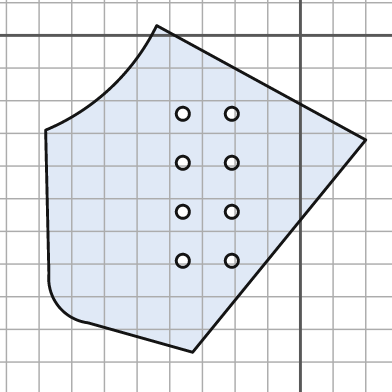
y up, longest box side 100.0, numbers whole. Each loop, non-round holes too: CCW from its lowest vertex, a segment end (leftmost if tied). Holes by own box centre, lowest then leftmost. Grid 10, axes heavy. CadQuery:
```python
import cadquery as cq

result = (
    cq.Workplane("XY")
    .moveTo(-33.0, -97.0)
    .lineTo(20.0, -32.0)
    .lineTo(-44.0, 3.0)
    .threePointArc((-58.0, -16.0), (-78.0, -29.0))
    .lineTo(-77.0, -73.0)
    .threePointArc((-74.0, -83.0), (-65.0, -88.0))
    .close()
    .moveTo(-36.0, -69.0)
    .circle(2.0)
    .moveTo(-21.0, -69.0)
    .circle(2.0)
    .moveTo(-36.0, -54.0)
    .circle(2.0)
    .moveTo(-21.0, -54.0)
    .circle(2.0)
    .moveTo(-36.0, -39.0)
    .circle(2.0)
    .moveTo(-21.0, -39.0)
    .circle(2.0)
    .moveTo(-36.0, -24.0)
    .circle(2.0)
    .moveTo(-21.0, -24.0)
    .circle(2.0)
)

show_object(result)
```